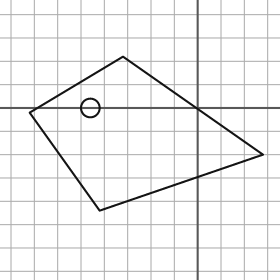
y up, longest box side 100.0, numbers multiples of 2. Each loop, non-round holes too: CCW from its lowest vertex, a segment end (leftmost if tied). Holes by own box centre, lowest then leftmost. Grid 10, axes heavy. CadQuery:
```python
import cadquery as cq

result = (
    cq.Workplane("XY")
    .moveTo(-42.0, -44.0)
    .lineTo(28.0, -20.0)
    .lineTo(-32.0, 22.0)
    .lineTo(-72.0, -2.0)
    .close()
    .moveTo(-46.0, 0.0)
    .circle(4.0)
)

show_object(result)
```